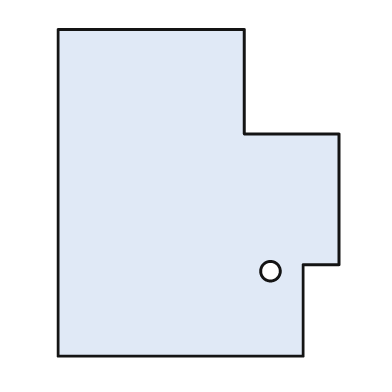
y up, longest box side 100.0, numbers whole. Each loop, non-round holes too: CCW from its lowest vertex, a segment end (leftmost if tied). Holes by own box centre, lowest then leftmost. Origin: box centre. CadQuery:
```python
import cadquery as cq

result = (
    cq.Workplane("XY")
    .moveTo(-43.0, -50.0)
    .lineTo(32.0, -50.0)
    .lineTo(32.0, -22.0)
    .lineTo(43.0, -22.0)
    .lineTo(43.0, 18.0)
    .lineTo(14.0, 18.0)
    .lineTo(14.0, 50.0)
    .lineTo(-43.0, 50.0)
    .close()
    .moveTo(22.0, -24.0)
    .circle(3.0)
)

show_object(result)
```